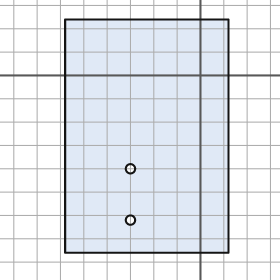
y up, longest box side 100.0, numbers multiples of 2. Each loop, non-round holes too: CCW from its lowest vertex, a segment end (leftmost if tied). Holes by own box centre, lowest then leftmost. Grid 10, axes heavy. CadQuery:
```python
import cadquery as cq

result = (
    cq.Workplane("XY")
    .moveTo(-58.0, -76.0)
    .lineTo(12.0, -76.0)
    .lineTo(12.0, 24.0)
    .lineTo(-58.0, 24.0)
    .close()
    .moveTo(-30.0, -62.0)
    .circle(2.0)
    .moveTo(-30.0, -40.0)
    .circle(2.0)
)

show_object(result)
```